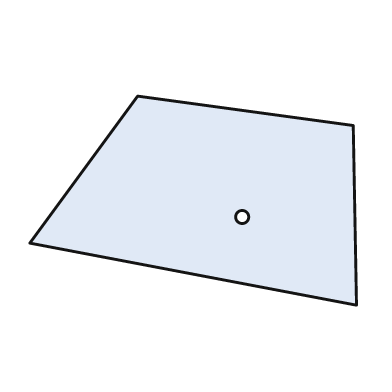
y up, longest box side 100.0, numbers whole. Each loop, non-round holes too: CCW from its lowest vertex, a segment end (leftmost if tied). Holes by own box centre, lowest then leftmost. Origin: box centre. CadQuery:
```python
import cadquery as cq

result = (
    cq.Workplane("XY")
    .moveTo(50.0, -32.0)
    .lineTo(49.0, 23.0)
    .lineTo(-17.0, 32.0)
    .lineTo(-50.0, -13.0)
    .close()
    .moveTo(15.0, -5.0)
    .circle(2.0)
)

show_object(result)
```